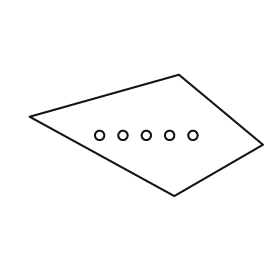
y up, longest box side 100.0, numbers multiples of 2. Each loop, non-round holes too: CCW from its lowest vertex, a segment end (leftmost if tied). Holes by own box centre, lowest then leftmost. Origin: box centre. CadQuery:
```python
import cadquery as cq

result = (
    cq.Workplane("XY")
    .moveTo(12.0, -26.0)
    .lineTo(50.0, -4.0)
    .lineTo(14.0, 26.0)
    .lineTo(-50.0, 8.0)
    .close()
    .moveTo(-20.0, 0.0)
    .circle(2.0)
    .moveTo(-10.0, 0.0)
    .circle(2.0)
    .moveTo(0.0, 0.0)
    .circle(2.0)
    .moveTo(10.0, 0.0)
    .circle(2.0)
    .moveTo(20.0, 0.0)
    .circle(2.0)
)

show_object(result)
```